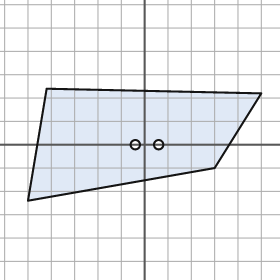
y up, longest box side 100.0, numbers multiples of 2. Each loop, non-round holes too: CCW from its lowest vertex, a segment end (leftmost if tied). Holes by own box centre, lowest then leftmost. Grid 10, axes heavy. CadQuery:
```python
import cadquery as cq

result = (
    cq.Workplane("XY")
    .moveTo(-50.0, -24.0)
    .lineTo(30.0, -10.0)
    .lineTo(50.0, 22.0)
    .lineTo(-42.0, 24.0)
    .close()
    .moveTo(-4.0, 0.0)
    .circle(2.0)
    .moveTo(6.0, 0.0)
    .circle(2.0)
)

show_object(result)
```